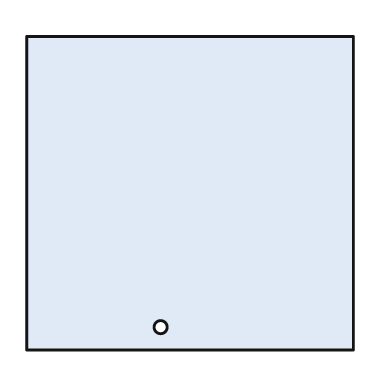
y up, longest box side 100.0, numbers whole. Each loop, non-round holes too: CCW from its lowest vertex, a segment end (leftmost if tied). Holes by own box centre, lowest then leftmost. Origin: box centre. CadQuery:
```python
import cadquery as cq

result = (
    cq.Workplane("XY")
    .moveTo(-50.0, -48.0)
    .lineTo(50.0, -48.0)
    .lineTo(50.0, 48.0)
    .lineTo(-50.0, 48.0)
    .close()
    .moveTo(-9.0, -41.0)
    .circle(2.0)
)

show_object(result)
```